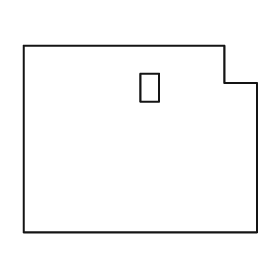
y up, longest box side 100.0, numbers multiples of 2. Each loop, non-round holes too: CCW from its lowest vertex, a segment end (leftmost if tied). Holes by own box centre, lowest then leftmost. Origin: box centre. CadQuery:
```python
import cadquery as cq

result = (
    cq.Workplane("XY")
    .moveTo(-50.0, -40.0)
    .lineTo(50.0, -40.0)
    .lineTo(50.0, 24.0)
    .lineTo(36.0, 24.0)
    .lineTo(36.0, 40.0)
    .lineTo(-50.0, 40.0)
    .close()
    .moveTo(0.0, 16.0)
    .lineTo(8.0, 16.0)
    .lineTo(8.0, 28.0)
    .lineTo(0.0, 28.0)
    .close()
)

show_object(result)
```